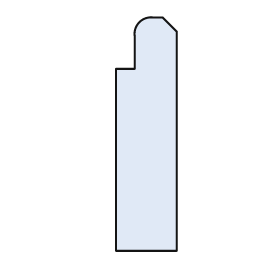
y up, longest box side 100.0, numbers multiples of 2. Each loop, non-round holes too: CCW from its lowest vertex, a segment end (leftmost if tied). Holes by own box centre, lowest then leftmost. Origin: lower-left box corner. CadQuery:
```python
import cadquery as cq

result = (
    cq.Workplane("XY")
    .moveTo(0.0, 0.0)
    .lineTo(26.0, 0.0)
    .lineTo(26.0, 94.0)
    .lineTo(20.0, 100.0)
    .lineTo(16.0, 100.0)
    .threePointArc((10.0, 98.0), (8.0, 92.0))
    .lineTo(8.0, 78.0)
    .lineTo(0.0, 78.0)
    .close()
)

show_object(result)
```